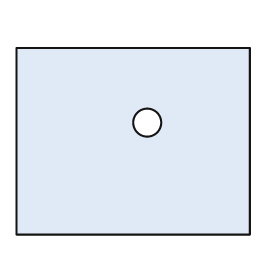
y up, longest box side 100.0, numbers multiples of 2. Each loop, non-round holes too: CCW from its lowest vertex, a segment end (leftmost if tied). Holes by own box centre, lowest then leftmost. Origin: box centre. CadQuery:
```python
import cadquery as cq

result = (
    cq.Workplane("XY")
    .moveTo(-50.0, -40.0)
    .lineTo(50.0, -40.0)
    .lineTo(50.0, 40.0)
    .lineTo(-50.0, 40.0)
    .close()
    .moveTo(6.0, 8.0)
    .circle(6.0)
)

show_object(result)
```